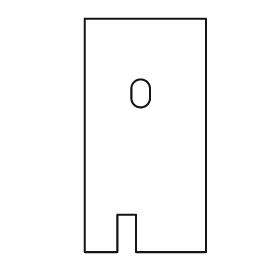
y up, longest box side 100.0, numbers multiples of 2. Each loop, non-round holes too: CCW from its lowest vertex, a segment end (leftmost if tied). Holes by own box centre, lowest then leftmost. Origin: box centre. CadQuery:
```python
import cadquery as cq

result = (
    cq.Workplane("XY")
    .moveTo(-26.0, -50.0)
    .lineTo(-12.0, -50.0)
    .lineTo(-12.0, -34.0)
    .lineTo(-4.0, -34.0)
    .lineTo(-4.0, -50.0)
    .lineTo(26.0, -50.0)
    .lineTo(26.0, 50.0)
    .lineTo(-26.0, 50.0)
    .close()
    .moveTo(-6.0, 16.0)
    .threePointArc((-2.0, 12.0), (2.0, 16.0))
    .lineTo(2.0, 20.0)
    .threePointArc((-2.0, 24.0), (-6.0, 20.0))
    .close()
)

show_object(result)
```